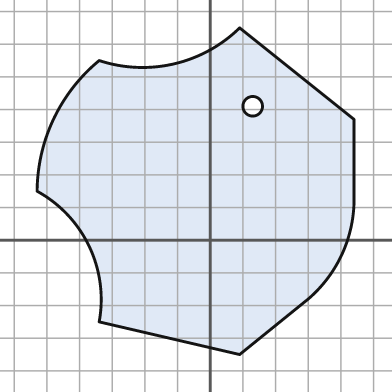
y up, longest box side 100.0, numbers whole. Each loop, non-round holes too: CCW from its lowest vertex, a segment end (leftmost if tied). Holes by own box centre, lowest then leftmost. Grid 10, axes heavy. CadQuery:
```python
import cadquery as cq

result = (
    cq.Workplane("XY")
    .moveTo(9.0, -35.0)
    .lineTo(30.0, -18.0)
    .threePointArc((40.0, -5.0), (44.0, 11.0))
    .lineTo(44.0, 37.0)
    .lineTo(9.0, 65.0)
    .threePointArc((-11.0, 54.0), (-34.0, 55.0))
    .threePointArc((-48.0, 37.0), (-53.0, 15.0))
    .threePointArc((-37.0, -2.0), (-34.0, -25.0))
    .close()
    .moveTo(13.0, 41.0)
    .circle(3.0)
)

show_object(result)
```